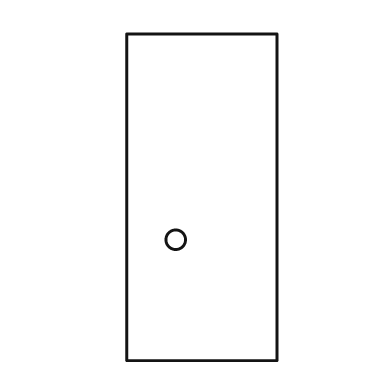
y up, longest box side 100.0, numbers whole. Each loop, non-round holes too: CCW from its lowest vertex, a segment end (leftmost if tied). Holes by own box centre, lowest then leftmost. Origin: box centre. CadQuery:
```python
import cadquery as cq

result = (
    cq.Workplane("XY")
    .moveTo(-23.0, -50.0)
    .lineTo(23.0, -50.0)
    .lineTo(23.0, 50.0)
    .lineTo(-23.0, 50.0)
    .close()
    .moveTo(-8.0, -13.0)
    .circle(3.0)
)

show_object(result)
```